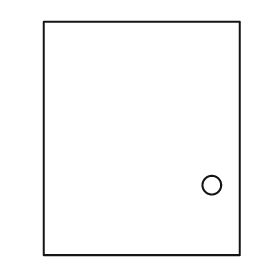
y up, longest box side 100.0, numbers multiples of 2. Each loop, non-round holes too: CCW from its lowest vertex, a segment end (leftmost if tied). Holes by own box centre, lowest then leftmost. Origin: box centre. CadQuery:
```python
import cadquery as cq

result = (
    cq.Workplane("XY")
    .moveTo(-42.0, -50.0)
    .lineTo(42.0, -50.0)
    .lineTo(42.0, 50.0)
    .lineTo(-42.0, 50.0)
    .close()
    .moveTo(30.0, -20.0)
    .circle(4.0)
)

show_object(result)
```